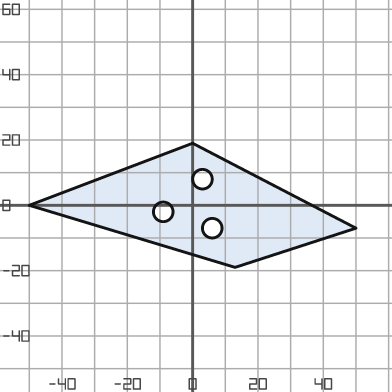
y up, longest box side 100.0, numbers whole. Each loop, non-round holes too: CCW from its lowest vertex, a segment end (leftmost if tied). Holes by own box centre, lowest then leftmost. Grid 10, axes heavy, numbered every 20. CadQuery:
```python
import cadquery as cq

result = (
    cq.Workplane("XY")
    .moveTo(13.0, -19.0)
    .lineTo(50.0, -7.0)
    .lineTo(0.0, 19.0)
    .lineTo(-50.0, 0.0)
    .close()
    .moveTo(6.0, -7.0)
    .circle(3.0)
    .moveTo(-9.0, -2.0)
    .circle(3.0)
    .moveTo(3.0, 8.0)
    .circle(3.0)
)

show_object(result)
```